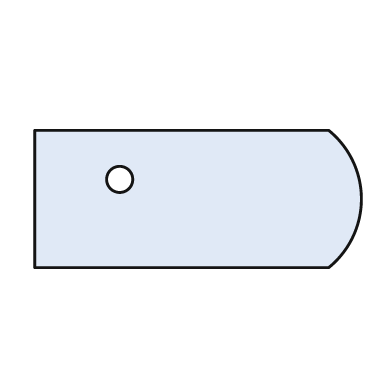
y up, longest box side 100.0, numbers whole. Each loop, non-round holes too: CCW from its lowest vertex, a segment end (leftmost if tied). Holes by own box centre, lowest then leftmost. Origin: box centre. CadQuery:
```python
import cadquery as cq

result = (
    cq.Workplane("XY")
    .moveTo(-50.0, -21.0)
    .lineTo(40.0, -21.0)
    .threePointArc((50.0, 0.0), (40.0, 21.0))
    .lineTo(-50.0, 21.0)
    .close()
    .moveTo(-24.0, 6.0)
    .circle(4.0)
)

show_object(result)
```